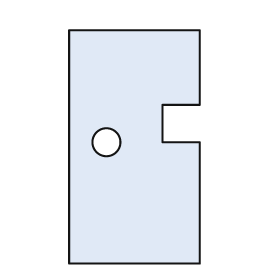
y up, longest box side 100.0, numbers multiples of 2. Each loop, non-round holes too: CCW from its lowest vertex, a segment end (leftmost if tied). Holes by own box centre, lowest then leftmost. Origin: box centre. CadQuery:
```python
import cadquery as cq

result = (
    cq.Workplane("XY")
    .moveTo(-28.0, -50.0)
    .lineTo(28.0, -50.0)
    .lineTo(28.0, 2.0)
    .lineTo(12.0, 2.0)
    .lineTo(12.0, 18.0)
    .lineTo(28.0, 18.0)
    .lineTo(28.0, 50.0)
    .lineTo(-28.0, 50.0)
    .close()
    .moveTo(-12.0, 2.0)
    .circle(6.0)
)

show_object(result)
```